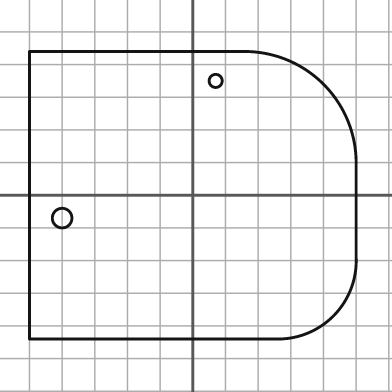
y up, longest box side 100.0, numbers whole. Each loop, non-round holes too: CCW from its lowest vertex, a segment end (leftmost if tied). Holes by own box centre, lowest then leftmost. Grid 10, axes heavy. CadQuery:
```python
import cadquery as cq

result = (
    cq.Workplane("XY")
    .moveTo(-50.0, -44.0)
    .lineTo(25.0, -44.0)
    .threePointArc((43.0, -37.0), (50.0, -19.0))
    .lineTo(50.0, 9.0)
    .threePointArc((40.0, 34.0), (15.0, 44.0))
    .lineTo(-50.0, 44.0)
    .close()
    .moveTo(-40.0, -7.0)
    .circle(3.0)
    .moveTo(7.0, 35.0)
    .circle(2.0)
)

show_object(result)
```